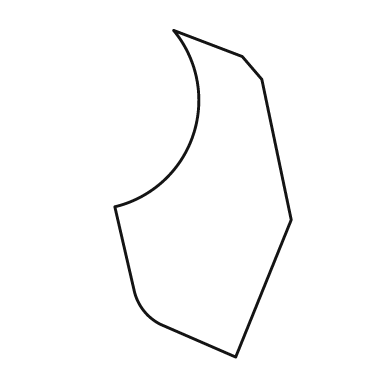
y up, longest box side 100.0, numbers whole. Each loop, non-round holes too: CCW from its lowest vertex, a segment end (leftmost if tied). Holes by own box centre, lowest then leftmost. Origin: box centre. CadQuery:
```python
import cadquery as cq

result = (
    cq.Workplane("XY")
    .moveTo(10.0, -50.0)
    .lineTo(27.0, -8.0)
    .lineTo(18.0, 35.0)
    .lineTo(12.0, 42.0)
    .lineTo(-9.0, 50.0)
    .threePointArc((-3.0, 18.0), (-27.0, -4.0))
    .lineTo(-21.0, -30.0)
    .threePointArc((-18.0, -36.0), (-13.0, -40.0))
    .close()
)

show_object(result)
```